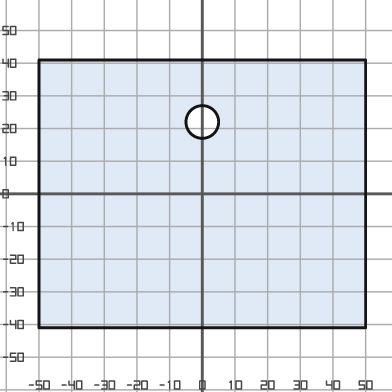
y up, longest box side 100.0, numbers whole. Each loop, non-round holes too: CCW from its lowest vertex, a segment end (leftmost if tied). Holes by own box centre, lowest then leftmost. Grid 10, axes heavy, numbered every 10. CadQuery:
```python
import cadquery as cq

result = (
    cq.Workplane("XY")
    .moveTo(-50.0, -41.0)
    .lineTo(50.0, -41.0)
    .lineTo(50.0, 41.0)
    .lineTo(-50.0, 41.0)
    .close()
    .moveTo(0.0, 22.0)
    .circle(5.0)
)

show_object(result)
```